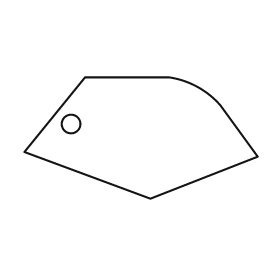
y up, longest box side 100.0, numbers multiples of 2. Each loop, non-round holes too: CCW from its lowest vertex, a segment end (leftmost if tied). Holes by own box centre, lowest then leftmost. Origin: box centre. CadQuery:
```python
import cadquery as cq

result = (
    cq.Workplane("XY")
    .moveTo(4.0, -26.0)
    .lineTo(50.0, -8.0)
    .lineTo(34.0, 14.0)
    .threePointArc((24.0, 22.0), (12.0, 26.0))
    .lineTo(-24.0, 26.0)
    .lineTo(-50.0, -6.0)
    .close()
    .moveTo(-30.0, 6.0)
    .circle(4.0)
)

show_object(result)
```